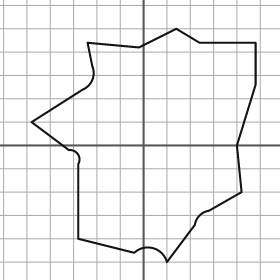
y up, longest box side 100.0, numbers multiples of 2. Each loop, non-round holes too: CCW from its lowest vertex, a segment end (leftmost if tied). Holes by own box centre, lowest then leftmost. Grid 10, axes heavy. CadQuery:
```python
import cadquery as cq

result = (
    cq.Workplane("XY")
    .moveTo(10.0, -50.0)
    .lineTo(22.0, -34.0)
    .threePointArc((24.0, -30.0), (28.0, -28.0))
    .lineTo(42.0, -20.0)
    .lineTo(40.0, 0.0)
    .lineTo(48.0, 26.0)
    .lineTo(48.0, 44.0)
    .lineTo(24.0, 44.0)
    .lineTo(14.0, 50.0)
    .lineTo(-2.0, 42.0)
    .lineTo(-24.0, 44.0)
    .lineTo(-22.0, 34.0)
    .threePointArc((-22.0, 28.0), (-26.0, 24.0))
    .lineTo(-48.0, 10.0)
    .lineTo(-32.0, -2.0)
    .threePointArc((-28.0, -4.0), (-28.0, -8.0))
    .lineTo(-28.0, -40.0)
    .lineTo(-4.0, -46.0)
    .threePointArc((4.0, -44.0), (10.0, -50.0))
    .close()
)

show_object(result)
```